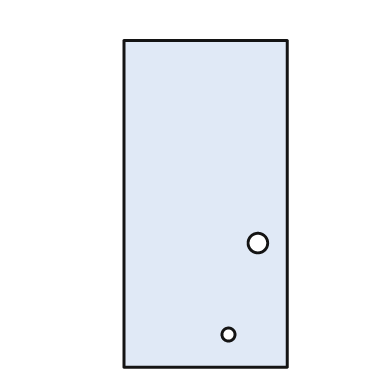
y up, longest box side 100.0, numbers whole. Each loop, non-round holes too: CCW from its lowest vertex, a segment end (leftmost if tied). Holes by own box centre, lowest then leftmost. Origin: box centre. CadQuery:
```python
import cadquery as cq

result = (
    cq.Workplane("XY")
    .moveTo(-25.0, -50.0)
    .lineTo(25.0, -50.0)
    .lineTo(25.0, 50.0)
    .lineTo(-25.0, 50.0)
    .close()
    .moveTo(7.0, -40.0)
    .circle(2.0)
    .moveTo(16.0, -12.0)
    .circle(3.0)
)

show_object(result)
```